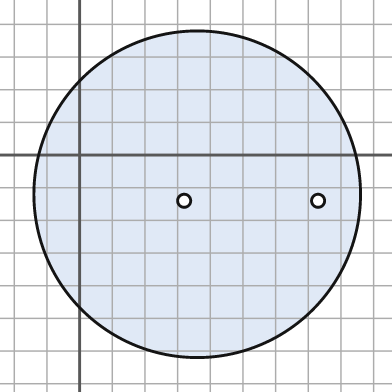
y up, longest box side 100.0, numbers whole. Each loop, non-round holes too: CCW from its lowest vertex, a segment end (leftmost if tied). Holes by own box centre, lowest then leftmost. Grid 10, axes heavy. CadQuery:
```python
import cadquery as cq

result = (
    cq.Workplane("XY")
    .moveTo(36.0, -12.0)
    .circle(50.0)
    .moveTo(32.0, -14.0)
    .circle(2.0)
    .moveTo(73.0, -14.0)
    .circle(2.0)
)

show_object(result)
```